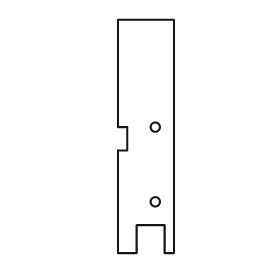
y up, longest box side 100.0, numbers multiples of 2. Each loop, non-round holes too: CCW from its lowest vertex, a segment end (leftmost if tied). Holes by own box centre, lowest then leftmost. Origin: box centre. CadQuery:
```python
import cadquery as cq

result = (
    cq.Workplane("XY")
    .moveTo(-12.0, -50.0)
    .lineTo(-4.0, -50.0)
    .lineTo(-4.0, -38.0)
    .lineTo(8.0, -38.0)
    .lineTo(8.0, -50.0)
    .lineTo(12.0, -50.0)
    .lineTo(12.0, 50.0)
    .lineTo(-12.0, 50.0)
    .lineTo(-12.0, 4.0)
    .lineTo(-8.0, 4.0)
    .lineTo(-8.0, -6.0)
    .lineTo(-12.0, -6.0)
    .close()
    .moveTo(4.0, -28.0)
    .circle(2.0)
    .moveTo(4.0, 4.0)
    .circle(2.0)
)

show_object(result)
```